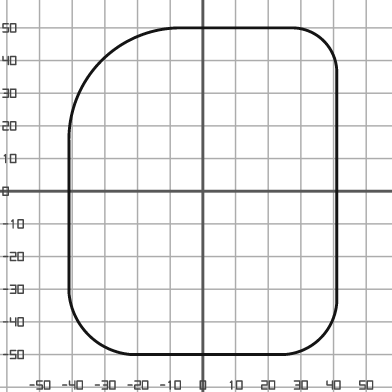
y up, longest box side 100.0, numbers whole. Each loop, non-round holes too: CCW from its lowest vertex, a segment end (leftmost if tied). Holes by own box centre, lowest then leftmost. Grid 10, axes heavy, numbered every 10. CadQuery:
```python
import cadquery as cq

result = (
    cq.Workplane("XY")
    .moveTo(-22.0, -50.0)
    .lineTo(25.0, -50.0)
    .threePointArc((36.0, -45.0), (41.0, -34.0))
    .lineTo(41.0, 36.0)
    .threePointArc((37.0, 46.0), (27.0, 50.0))
    .lineTo(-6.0, 50.0)
    .threePointArc((-31.0, 40.0), (-41.0, 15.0))
    .lineTo(-41.0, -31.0)
    .threePointArc((-35.0, -44.0), (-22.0, -50.0))
    .close()
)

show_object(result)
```